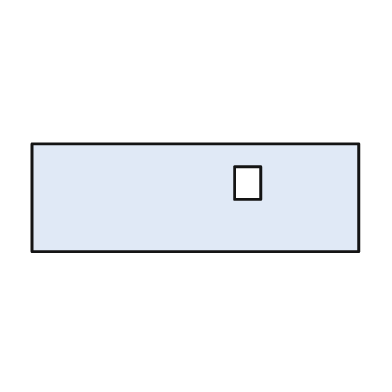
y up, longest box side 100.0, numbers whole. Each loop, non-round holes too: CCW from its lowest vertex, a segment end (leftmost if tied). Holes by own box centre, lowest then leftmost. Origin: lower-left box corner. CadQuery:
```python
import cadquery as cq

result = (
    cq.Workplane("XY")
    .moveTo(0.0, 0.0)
    .lineTo(100.0, 0.0)
    .lineTo(100.0, 33.0)
    .lineTo(0.0, 33.0)
    .close()
    .moveTo(62.0, 16.0)
    .lineTo(70.0, 16.0)
    .lineTo(70.0, 26.0)
    .lineTo(62.0, 26.0)
    .close()
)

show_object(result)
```